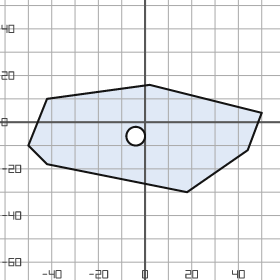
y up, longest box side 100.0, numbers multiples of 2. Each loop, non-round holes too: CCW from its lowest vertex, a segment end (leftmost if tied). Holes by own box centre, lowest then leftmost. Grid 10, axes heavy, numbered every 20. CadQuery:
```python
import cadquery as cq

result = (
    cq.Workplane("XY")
    .moveTo(18.0, -30.0)
    .lineTo(44.0, -12.0)
    .lineTo(50.0, 4.0)
    .lineTo(2.0, 16.0)
    .lineTo(-42.0, 10.0)
    .lineTo(-50.0, -10.0)
    .lineTo(-42.0, -18.0)
    .close()
    .moveTo(-4.0, -6.0)
    .circle(4.0)
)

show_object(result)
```